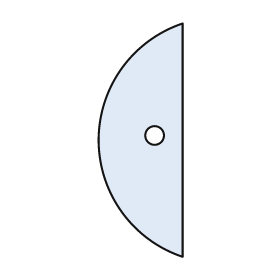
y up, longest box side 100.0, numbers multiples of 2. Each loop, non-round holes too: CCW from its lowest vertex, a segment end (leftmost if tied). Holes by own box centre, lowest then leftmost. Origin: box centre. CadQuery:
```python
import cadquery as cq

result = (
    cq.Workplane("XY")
    .moveTo(18.0, -50.0)
    .lineTo(18.0, 50.0)
    .threePointArc((-18.0, 0.0), (18.0, -50.0))
    .close()
    .moveTo(6.0, 2.0)
    .circle(4.0)
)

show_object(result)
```